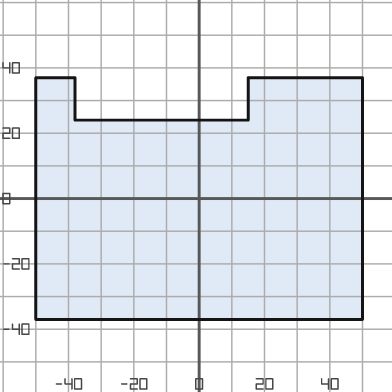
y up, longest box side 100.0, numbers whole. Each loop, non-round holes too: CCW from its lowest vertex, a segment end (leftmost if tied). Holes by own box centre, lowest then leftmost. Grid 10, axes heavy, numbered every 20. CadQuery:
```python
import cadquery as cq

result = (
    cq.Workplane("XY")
    .moveTo(-50.0, -37.0)
    .lineTo(50.0, -37.0)
    .lineTo(50.0, 37.0)
    .lineTo(15.0, 37.0)
    .lineTo(15.0, 24.0)
    .lineTo(-38.0, 24.0)
    .lineTo(-38.0, 37.0)
    .lineTo(-50.0, 37.0)
    .close()
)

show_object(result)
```